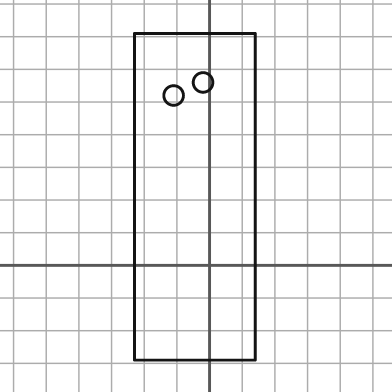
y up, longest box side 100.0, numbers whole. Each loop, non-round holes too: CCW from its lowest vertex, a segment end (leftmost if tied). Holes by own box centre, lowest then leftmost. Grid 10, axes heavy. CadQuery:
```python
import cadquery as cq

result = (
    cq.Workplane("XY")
    .moveTo(-23.0, -29.0)
    .lineTo(14.0, -29.0)
    .lineTo(14.0, 71.0)
    .lineTo(-23.0, 71.0)
    .close()
    .moveTo(-11.0, 52.0)
    .circle(3.0)
    .moveTo(-2.0, 56.0)
    .circle(3.0)
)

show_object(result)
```